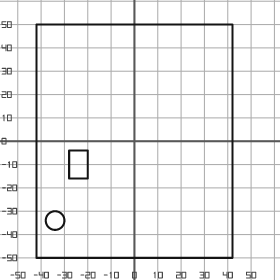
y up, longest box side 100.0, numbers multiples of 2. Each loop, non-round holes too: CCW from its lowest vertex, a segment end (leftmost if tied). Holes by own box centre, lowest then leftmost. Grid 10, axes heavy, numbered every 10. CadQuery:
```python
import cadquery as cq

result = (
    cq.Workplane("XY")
    .moveTo(-42.0, -50.0)
    .lineTo(42.0, -50.0)
    .lineTo(42.0, 50.0)
    .lineTo(-42.0, 50.0)
    .close()
    .moveTo(-34.0, -34.0)
    .circle(4.0)
    .moveTo(-28.0, -16.0)
    .lineTo(-20.0, -16.0)
    .lineTo(-20.0, -4.0)
    .lineTo(-28.0, -4.0)
    .close()
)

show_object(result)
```